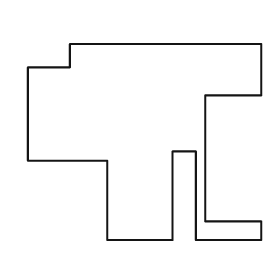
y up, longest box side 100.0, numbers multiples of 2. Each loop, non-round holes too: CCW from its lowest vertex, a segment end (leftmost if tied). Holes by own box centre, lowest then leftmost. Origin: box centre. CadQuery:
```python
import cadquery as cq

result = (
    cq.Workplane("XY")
    .moveTo(-16.0, -42.0)
    .lineTo(12.0, -42.0)
    .lineTo(12.0, -4.0)
    .lineTo(22.0, -4.0)
    .lineTo(22.0, -42.0)
    .lineTo(50.0, -42.0)
    .lineTo(50.0, -34.0)
    .lineTo(26.0, -34.0)
    .lineTo(26.0, 20.0)
    .lineTo(50.0, 20.0)
    .lineTo(50.0, 42.0)
    .lineTo(-32.0, 42.0)
    .lineTo(-32.0, 32.0)
    .lineTo(-50.0, 32.0)
    .lineTo(-50.0, -8.0)
    .lineTo(-16.0, -8.0)
    .close()
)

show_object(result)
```